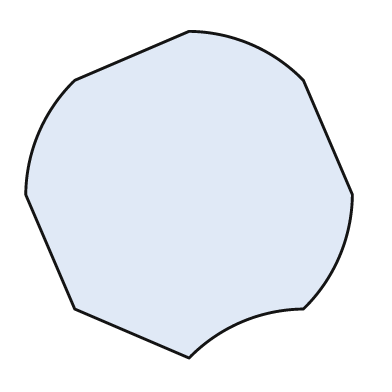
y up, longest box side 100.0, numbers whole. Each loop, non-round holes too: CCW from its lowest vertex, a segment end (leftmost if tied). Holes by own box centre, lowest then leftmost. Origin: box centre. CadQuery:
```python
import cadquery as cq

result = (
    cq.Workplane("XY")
    .moveTo(0.0, -50.0)
    .threePointArc((16.0, -39.0), (35.0, -35.0))
    .threePointArc((46.0, -19.0), (50.0, 0.0))
    .lineTo(35.0, 35.0)
    .threePointArc((19.0, 46.0), (0.0, 50.0))
    .lineTo(-35.0, 35.0)
    .threePointArc((-46.0, 19.0), (-50.0, 0.0))
    .lineTo(-35.0, -35.0)
    .close()
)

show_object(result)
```